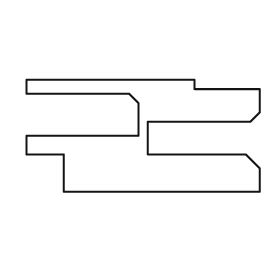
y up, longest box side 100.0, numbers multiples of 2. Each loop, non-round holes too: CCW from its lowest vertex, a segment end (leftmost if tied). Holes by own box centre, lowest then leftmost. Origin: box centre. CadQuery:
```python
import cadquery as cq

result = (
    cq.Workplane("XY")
    .moveTo(-34.0, -24.0)
    .lineTo(50.0, -24.0)
    .lineTo(50.0, -14.0)
    .lineTo(44.0, -8.0)
    .lineTo(2.0, -8.0)
    .lineTo(2.0, 6.0)
    .lineTo(46.0, 6.0)
    .lineTo(50.0, 10.0)
    .lineTo(50.0, 20.0)
    .lineTo(22.0, 20.0)
    .lineTo(22.0, 24.0)
    .lineTo(-50.0, 24.0)
    .lineTo(-50.0, 18.0)
    .lineTo(-6.0, 18.0)
    .lineTo(-2.0, 14.0)
    .lineTo(-2.0, 0.0)
    .lineTo(-50.0, 0.0)
    .lineTo(-50.0, -8.0)
    .lineTo(-34.0, -8.0)
    .close()
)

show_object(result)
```